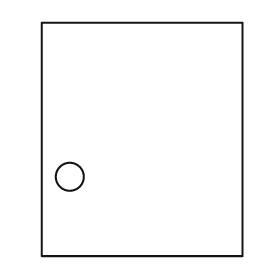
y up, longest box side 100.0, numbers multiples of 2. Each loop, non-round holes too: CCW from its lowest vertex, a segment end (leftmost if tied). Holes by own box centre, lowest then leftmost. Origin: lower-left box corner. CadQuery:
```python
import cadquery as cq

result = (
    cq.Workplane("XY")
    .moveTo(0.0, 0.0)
    .lineTo(86.0, 0.0)
    .lineTo(86.0, 100.0)
    .lineTo(0.0, 100.0)
    .close()
    .moveTo(12.0, 34.0)
    .circle(6.0)
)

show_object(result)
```